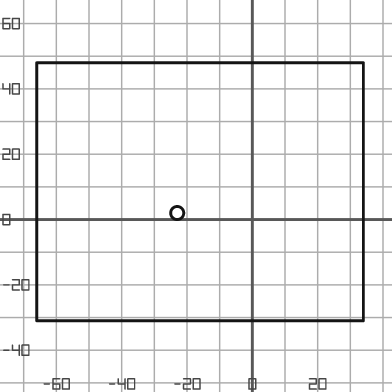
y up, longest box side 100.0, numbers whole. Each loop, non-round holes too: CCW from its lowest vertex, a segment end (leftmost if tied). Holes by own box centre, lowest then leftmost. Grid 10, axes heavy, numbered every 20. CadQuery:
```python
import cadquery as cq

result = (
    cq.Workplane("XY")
    .moveTo(-66.0, -31.0)
    .lineTo(34.0, -31.0)
    .lineTo(34.0, 48.0)
    .lineTo(-66.0, 48.0)
    .close()
    .moveTo(-23.0, 2.0)
    .circle(2.0)
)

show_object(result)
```